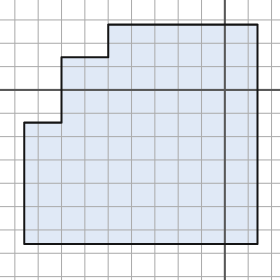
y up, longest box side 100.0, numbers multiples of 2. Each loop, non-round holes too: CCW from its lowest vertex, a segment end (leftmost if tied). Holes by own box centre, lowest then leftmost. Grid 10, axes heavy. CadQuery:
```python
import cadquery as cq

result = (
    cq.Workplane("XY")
    .moveTo(-86.0, -66.0)
    .lineTo(14.0, -66.0)
    .lineTo(14.0, 28.0)
    .lineTo(-50.0, 28.0)
    .lineTo(-50.0, 14.0)
    .lineTo(-70.0, 14.0)
    .lineTo(-70.0, -14.0)
    .lineTo(-86.0, -14.0)
    .close()
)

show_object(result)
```